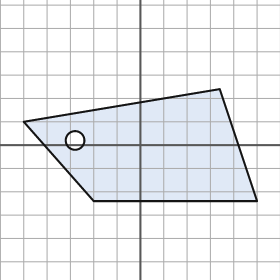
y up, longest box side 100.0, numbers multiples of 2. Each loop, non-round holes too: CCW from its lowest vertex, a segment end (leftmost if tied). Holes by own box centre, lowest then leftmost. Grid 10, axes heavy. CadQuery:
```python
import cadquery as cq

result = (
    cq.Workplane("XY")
    .moveTo(-20.0, -24.0)
    .lineTo(50.0, -24.0)
    .lineTo(34.0, 24.0)
    .lineTo(-50.0, 10.0)
    .close()
    .moveTo(-28.0, 2.0)
    .circle(4.0)
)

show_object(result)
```